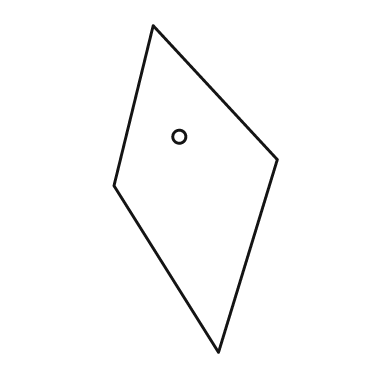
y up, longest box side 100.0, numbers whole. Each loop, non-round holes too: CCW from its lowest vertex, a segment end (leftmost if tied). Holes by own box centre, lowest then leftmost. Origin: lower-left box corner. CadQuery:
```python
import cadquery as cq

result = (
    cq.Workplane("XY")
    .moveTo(32.0, 0.0)
    .lineTo(50.0, 59.0)
    .lineTo(12.0, 100.0)
    .lineTo(0.0, 51.0)
    .close()
    .moveTo(20.0, 66.0)
    .circle(2.0)
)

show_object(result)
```